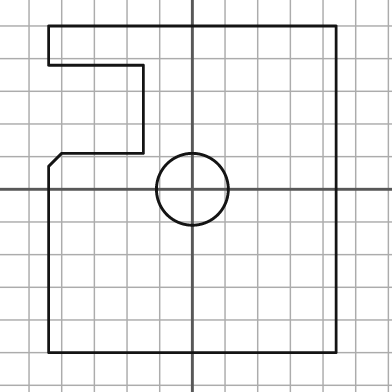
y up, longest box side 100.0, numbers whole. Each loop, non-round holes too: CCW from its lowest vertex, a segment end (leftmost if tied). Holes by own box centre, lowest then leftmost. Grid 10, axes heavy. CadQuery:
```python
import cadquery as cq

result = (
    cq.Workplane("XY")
    .moveTo(-44.0, -50.0)
    .lineTo(44.0, -50.0)
    .lineTo(44.0, 50.0)
    .lineTo(-44.0, 50.0)
    .lineTo(-44.0, 38.0)
    .lineTo(-15.0, 38.0)
    .lineTo(-15.0, 11.0)
    .lineTo(-40.0, 11.0)
    .lineTo(-44.0, 7.0)
    .close()
    .moveTo(0.0, 0.0)
    .circle(11.0)
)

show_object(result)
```